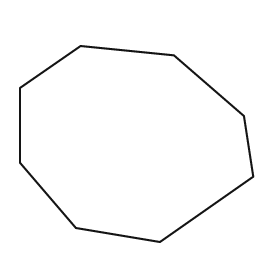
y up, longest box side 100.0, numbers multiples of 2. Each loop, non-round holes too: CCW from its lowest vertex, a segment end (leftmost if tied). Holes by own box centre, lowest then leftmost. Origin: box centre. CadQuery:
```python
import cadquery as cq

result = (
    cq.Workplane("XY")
    .moveTo(10.0, -42.0)
    .lineTo(50.0, -14.0)
    .lineTo(46.0, 12.0)
    .lineTo(16.0, 38.0)
    .lineTo(-24.0, 42.0)
    .lineTo(-50.0, 24.0)
    .lineTo(-50.0, -8.0)
    .lineTo(-26.0, -36.0)
    .close()
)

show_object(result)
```